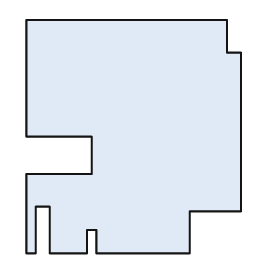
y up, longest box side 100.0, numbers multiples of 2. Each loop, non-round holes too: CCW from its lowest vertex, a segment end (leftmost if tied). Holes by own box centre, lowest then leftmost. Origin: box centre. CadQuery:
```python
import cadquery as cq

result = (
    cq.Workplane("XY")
    .moveTo(-46.0, -50.0)
    .lineTo(-42.0, -50.0)
    .lineTo(-42.0, -30.0)
    .lineTo(-36.0, -30.0)
    .lineTo(-36.0, -50.0)
    .lineTo(-20.0, -50.0)
    .lineTo(-20.0, -40.0)
    .lineTo(-16.0, -40.0)
    .lineTo(-16.0, -50.0)
    .lineTo(24.0, -50.0)
    .lineTo(24.0, -32.0)
    .lineTo(46.0, -32.0)
    .lineTo(46.0, 36.0)
    .lineTo(40.0, 36.0)
    .lineTo(40.0, 50.0)
    .lineTo(-46.0, 50.0)
    .lineTo(-46.0, 0.0)
    .lineTo(-18.0, 0.0)
    .lineTo(-18.0, -16.0)
    .lineTo(-46.0, -16.0)
    .close()
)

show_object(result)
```